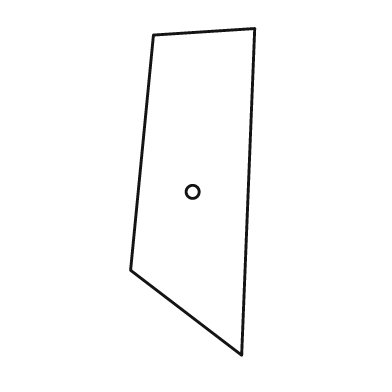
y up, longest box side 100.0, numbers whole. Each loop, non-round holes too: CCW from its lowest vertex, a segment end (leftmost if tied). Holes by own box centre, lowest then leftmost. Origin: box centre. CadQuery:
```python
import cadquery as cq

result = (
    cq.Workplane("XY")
    .moveTo(15.0, -50.0)
    .lineTo(19.0, 50.0)
    .lineTo(-12.0, 48.0)
    .lineTo(-19.0, -24.0)
    .close()
    .moveTo(0.0, 0.0)
    .circle(2.0)
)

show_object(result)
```